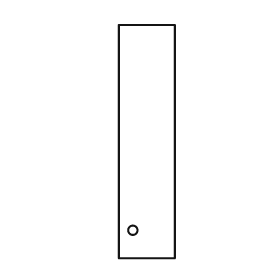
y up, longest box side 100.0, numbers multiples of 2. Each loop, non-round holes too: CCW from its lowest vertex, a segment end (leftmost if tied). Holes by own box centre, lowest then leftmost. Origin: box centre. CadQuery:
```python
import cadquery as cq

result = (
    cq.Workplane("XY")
    .moveTo(-12.0, -50.0)
    .lineTo(12.0, -50.0)
    .lineTo(12.0, 50.0)
    .lineTo(-12.0, 50.0)
    .close()
    .moveTo(-6.0, -38.0)
    .circle(2.0)
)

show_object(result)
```